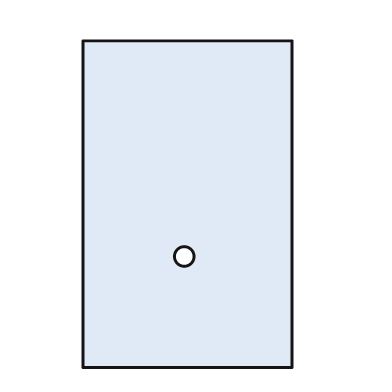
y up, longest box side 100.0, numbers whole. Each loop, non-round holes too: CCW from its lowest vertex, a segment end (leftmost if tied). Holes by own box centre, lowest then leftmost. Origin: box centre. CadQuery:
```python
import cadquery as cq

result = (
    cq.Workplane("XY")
    .moveTo(-32.0, -50.0)
    .lineTo(32.0, -50.0)
    .lineTo(32.0, 50.0)
    .lineTo(-32.0, 50.0)
    .close()
    .moveTo(-1.0, -16.0)
    .circle(3.0)
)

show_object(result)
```